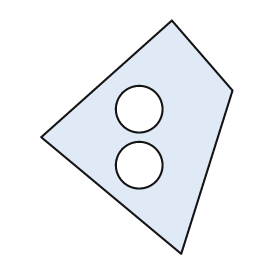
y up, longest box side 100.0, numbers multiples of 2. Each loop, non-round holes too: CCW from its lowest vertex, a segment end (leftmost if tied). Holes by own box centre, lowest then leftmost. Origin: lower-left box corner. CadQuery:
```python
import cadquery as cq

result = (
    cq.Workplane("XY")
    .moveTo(60.0, 0.0)
    .lineTo(82.0, 70.0)
    .lineTo(56.0, 100.0)
    .lineTo(0.0, 50.0)
    .close()
    .moveTo(42.0, 38.0)
    .circle(10.0)
    .moveTo(42.0, 62.0)
    .circle(10.0)
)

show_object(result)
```